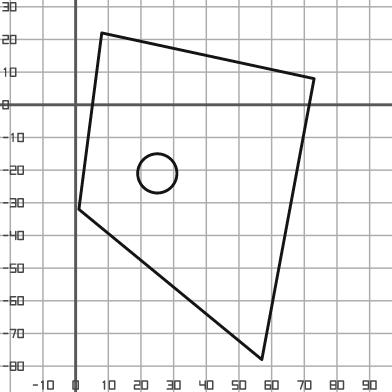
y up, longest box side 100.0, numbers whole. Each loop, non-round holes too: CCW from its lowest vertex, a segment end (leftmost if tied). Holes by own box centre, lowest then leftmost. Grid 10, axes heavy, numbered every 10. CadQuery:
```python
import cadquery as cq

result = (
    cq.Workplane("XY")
    .moveTo(57.0, -78.0)
    .lineTo(73.0, 8.0)
    .lineTo(8.0, 22.0)
    .lineTo(1.0, -32.0)
    .close()
    .moveTo(25.0, -21.0)
    .circle(6.0)
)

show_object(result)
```